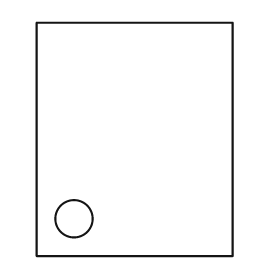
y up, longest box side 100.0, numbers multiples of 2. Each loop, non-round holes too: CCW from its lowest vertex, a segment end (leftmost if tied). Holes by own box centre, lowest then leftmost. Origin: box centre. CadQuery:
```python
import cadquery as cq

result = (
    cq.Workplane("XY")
    .moveTo(-42.0, -50.0)
    .lineTo(42.0, -50.0)
    .lineTo(42.0, 50.0)
    .lineTo(-42.0, 50.0)
    .close()
    .moveTo(-26.0, -34.0)
    .circle(8.0)
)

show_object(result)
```